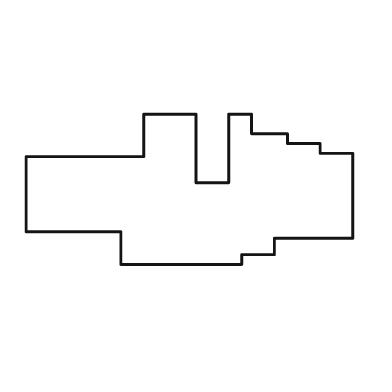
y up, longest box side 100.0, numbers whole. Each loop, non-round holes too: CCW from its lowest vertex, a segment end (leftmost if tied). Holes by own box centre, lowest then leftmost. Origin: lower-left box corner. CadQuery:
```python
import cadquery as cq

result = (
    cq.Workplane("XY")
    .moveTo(29.0, 0.0)
    .lineTo(66.0, 0.0)
    .lineTo(66.0, 3.0)
    .lineTo(76.0, 3.0)
    .lineTo(76.0, 8.0)
    .lineTo(100.0, 8.0)
    .lineTo(100.0, 34.0)
    .lineTo(90.0, 34.0)
    .lineTo(90.0, 37.0)
    .lineTo(80.0, 37.0)
    .lineTo(80.0, 40.0)
    .lineTo(69.0, 40.0)
    .lineTo(69.0, 46.0)
    .lineTo(62.0, 46.0)
    .lineTo(62.0, 25.0)
    .lineTo(52.0, 25.0)
    .lineTo(52.0, 46.0)
    .lineTo(36.0, 46.0)
    .lineTo(36.0, 33.0)
    .lineTo(0.0, 33.0)
    .lineTo(0.0, 10.0)
    .lineTo(29.0, 10.0)
    .close()
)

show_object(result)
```